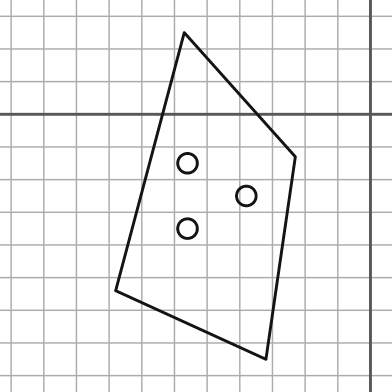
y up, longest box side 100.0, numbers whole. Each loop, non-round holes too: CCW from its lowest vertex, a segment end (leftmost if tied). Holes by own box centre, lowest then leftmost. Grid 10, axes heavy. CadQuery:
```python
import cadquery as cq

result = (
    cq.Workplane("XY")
    .moveTo(-32.0, -75.0)
    .lineTo(-23.0, -13.0)
    .lineTo(-57.0, 25.0)
    .lineTo(-78.0, -54.0)
    .close()
    .moveTo(-56.0, -35.0)
    .circle(3.0)
    .moveTo(-38.0, -25.0)
    .circle(3.0)
    .moveTo(-56.0, -15.0)
    .circle(3.0)
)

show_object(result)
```